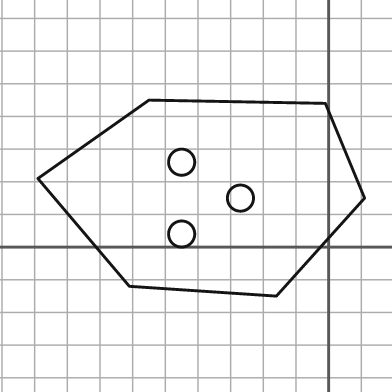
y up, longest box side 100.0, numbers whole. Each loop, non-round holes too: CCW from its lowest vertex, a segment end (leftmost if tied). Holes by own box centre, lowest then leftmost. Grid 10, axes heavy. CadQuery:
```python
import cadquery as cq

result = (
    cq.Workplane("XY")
    .moveTo(-16.0, -15.0)
    .lineTo(11.0, 15.0)
    .lineTo(-1.0, 44.0)
    .lineTo(-55.0, 45.0)
    .lineTo(-89.0, 21.0)
    .lineTo(-61.0, -12.0)
    .close()
    .moveTo(-45.0, 4.0)
    .circle(4.0)
    .moveTo(-27.0, 15.0)
    .circle(4.0)
    .moveTo(-45.0, 26.0)
    .circle(4.0)
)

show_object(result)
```